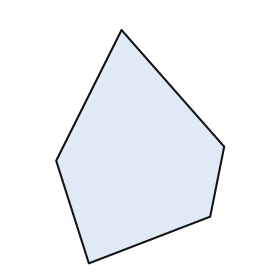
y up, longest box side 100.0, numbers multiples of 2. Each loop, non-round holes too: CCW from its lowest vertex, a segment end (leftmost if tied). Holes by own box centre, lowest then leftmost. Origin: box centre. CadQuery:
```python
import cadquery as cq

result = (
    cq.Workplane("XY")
    .moveTo(-22.0, -50.0)
    .lineTo(30.0, -30.0)
    .lineTo(36.0, 0.0)
    .lineTo(-8.0, 50.0)
    .lineTo(-36.0, -6.0)
    .close()
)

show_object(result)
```